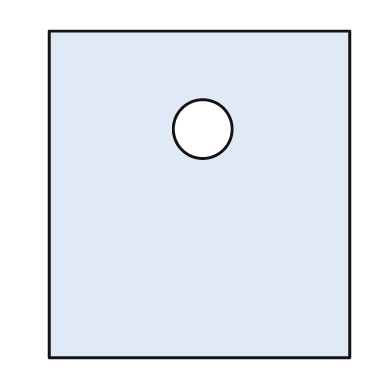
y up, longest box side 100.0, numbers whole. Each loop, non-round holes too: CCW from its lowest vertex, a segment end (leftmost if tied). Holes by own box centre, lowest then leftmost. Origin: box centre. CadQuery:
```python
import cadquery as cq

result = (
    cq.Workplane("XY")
    .moveTo(-46.0, -50.0)
    .lineTo(46.0, -50.0)
    .lineTo(46.0, 50.0)
    .lineTo(-46.0, 50.0)
    .close()
    .moveTo(1.0, 20.0)
    .circle(9.0)
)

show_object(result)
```